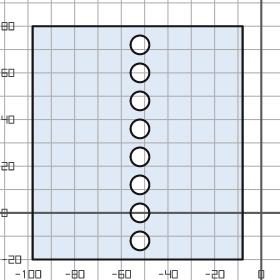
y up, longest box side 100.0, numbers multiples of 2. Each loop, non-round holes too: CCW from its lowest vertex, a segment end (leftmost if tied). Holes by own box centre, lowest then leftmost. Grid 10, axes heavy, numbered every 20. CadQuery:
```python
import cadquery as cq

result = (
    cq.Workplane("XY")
    .moveTo(-98.0, -20.0)
    .lineTo(-8.0, -20.0)
    .lineTo(-8.0, 80.0)
    .lineTo(-98.0, 80.0)
    .close()
    .moveTo(-52.0, -12.0)
    .circle(4.0)
    .moveTo(-52.0, 0.0)
    .circle(4.0)
    .moveTo(-52.0, 12.0)
    .circle(4.0)
    .moveTo(-52.0, 24.0)
    .circle(4.0)
    .moveTo(-52.0, 36.0)
    .circle(4.0)
    .moveTo(-52.0, 48.0)
    .circle(4.0)
    .moveTo(-52.0, 60.0)
    .circle(4.0)
    .moveTo(-52.0, 72.0)
    .circle(4.0)
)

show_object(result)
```